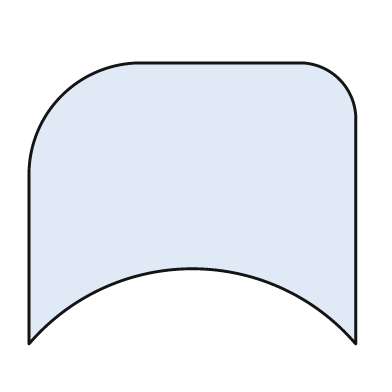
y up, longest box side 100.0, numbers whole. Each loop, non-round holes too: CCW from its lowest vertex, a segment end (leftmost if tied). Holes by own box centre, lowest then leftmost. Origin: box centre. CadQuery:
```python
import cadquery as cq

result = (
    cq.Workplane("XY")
    .moveTo(-50.0, -43.0)
    .threePointArc((0.0, -20.0), (50.0, -43.0))
    .lineTo(50.0, 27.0)
    .threePointArc((45.0, 38.0), (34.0, 43.0))
    .lineTo(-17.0, 43.0)
    .threePointArc((-40.0, 33.0), (-50.0, 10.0))
    .close()
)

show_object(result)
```